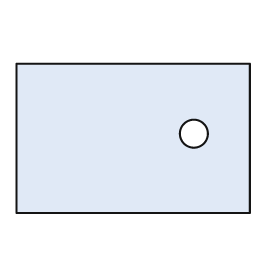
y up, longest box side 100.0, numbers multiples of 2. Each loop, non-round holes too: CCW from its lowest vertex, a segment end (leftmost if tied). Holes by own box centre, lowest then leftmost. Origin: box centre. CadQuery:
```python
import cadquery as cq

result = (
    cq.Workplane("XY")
    .moveTo(-50.0, -32.0)
    .lineTo(50.0, -32.0)
    .lineTo(50.0, 32.0)
    .lineTo(-50.0, 32.0)
    .close()
    .moveTo(26.0, 2.0)
    .circle(6.0)
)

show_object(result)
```